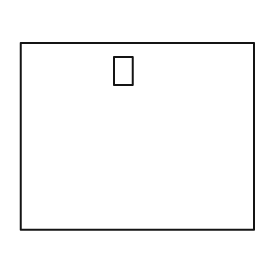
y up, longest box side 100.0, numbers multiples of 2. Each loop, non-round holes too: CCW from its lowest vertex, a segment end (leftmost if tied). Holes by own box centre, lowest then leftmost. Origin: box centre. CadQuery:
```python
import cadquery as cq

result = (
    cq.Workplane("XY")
    .moveTo(-50.0, -40.0)
    .lineTo(50.0, -40.0)
    .lineTo(50.0, 40.0)
    .lineTo(-50.0, 40.0)
    .close()
    .moveTo(-10.0, 22.0)
    .lineTo(-2.0, 22.0)
    .lineTo(-2.0, 34.0)
    .lineTo(-10.0, 34.0)
    .close()
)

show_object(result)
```